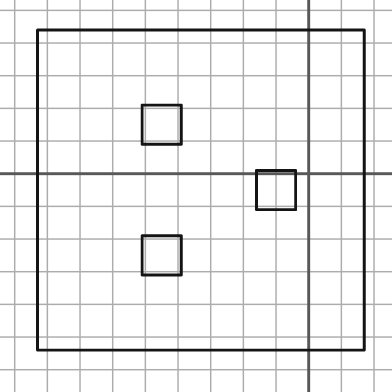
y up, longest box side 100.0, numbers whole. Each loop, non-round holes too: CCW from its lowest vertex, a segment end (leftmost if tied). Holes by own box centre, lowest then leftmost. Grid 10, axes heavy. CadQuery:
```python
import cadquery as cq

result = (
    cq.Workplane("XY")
    .moveTo(-83.0, -54.0)
    .lineTo(17.0, -54.0)
    .lineTo(17.0, 44.0)
    .lineTo(-83.0, 44.0)
    .close()
    .moveTo(-51.0, -31.0)
    .lineTo(-39.0, -31.0)
    .lineTo(-39.0, -19.0)
    .lineTo(-51.0, -19.0)
    .close()
    .moveTo(-16.0, -11.0)
    .lineTo(-4.0, -11.0)
    .lineTo(-4.0, 1.0)
    .lineTo(-16.0, 1.0)
    .close()
    .moveTo(-51.0, 9.0)
    .lineTo(-39.0, 9.0)
    .lineTo(-39.0, 21.0)
    .lineTo(-51.0, 21.0)
    .close()
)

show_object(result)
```